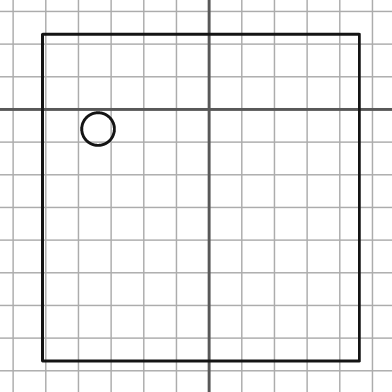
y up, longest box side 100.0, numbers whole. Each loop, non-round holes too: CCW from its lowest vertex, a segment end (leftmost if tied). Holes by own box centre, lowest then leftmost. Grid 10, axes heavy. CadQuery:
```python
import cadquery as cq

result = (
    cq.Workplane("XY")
    .moveTo(-51.0, -77.0)
    .lineTo(46.0, -77.0)
    .lineTo(46.0, 23.0)
    .lineTo(-51.0, 23.0)
    .close()
    .moveTo(-34.0, -6.0)
    .circle(5.0)
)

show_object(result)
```